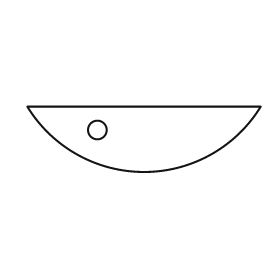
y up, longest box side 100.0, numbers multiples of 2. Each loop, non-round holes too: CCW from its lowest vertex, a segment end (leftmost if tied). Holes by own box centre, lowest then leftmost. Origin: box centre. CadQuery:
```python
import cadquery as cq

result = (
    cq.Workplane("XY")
    .moveTo(-50.0, 14.0)
    .threePointArc((0.0, -14.0), (50.0, 14.0))
    .close()
    .moveTo(-20.0, 4.0)
    .circle(4.0)
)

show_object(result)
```